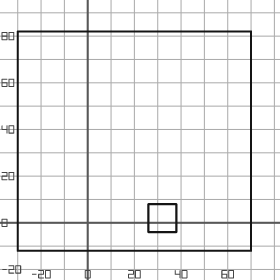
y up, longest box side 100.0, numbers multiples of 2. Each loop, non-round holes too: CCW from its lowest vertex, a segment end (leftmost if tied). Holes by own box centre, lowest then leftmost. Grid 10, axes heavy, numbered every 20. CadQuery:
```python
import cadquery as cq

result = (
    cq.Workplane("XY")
    .moveTo(-30.0, -12.0)
    .lineTo(70.0, -12.0)
    .lineTo(70.0, 82.0)
    .lineTo(-30.0, 82.0)
    .close()
    .moveTo(26.0, -4.0)
    .lineTo(38.0, -4.0)
    .lineTo(38.0, 8.0)
    .lineTo(26.0, 8.0)
    .close()
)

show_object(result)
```